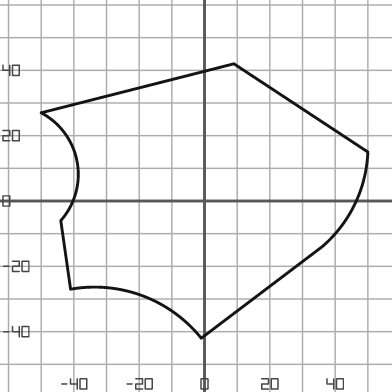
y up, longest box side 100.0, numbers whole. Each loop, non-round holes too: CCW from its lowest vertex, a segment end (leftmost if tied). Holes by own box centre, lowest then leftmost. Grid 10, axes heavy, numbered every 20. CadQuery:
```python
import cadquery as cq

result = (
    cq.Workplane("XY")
    .moveTo(-1.0, -42.0)
    .lineTo(36.0, -14.0)
    .threePointArc((46.0, -1.0), (50.0, 15.0))
    .lineTo(9.0, 42.0)
    .lineTo(-50.0, 27.0)
    .threePointArc((-39.0, 12.0), (-44.0, -6.0))
    .lineTo(-41.0, -27.0)
    .threePointArc((-19.0, -29.0), (-1.0, -42.0))
    .close()
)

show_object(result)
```